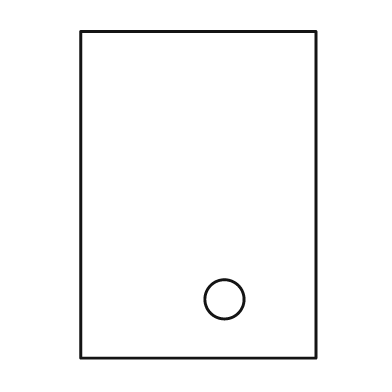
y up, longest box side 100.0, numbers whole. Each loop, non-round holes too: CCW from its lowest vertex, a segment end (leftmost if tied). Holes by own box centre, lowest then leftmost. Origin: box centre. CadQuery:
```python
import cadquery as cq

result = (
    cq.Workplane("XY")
    .moveTo(-36.0, -50.0)
    .lineTo(36.0, -50.0)
    .lineTo(36.0, 50.0)
    .lineTo(-36.0, 50.0)
    .close()
    .moveTo(8.0, -32.0)
    .circle(6.0)
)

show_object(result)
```